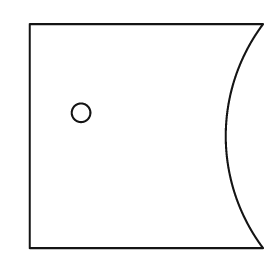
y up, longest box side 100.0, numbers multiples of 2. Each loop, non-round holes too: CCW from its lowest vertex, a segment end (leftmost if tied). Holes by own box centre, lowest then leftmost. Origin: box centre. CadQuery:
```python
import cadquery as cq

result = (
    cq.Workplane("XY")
    .moveTo(-50.0, -48.0)
    .lineTo(50.0, -48.0)
    .threePointArc((34.0, 0.0), (50.0, 48.0))
    .lineTo(-50.0, 48.0)
    .close()
    .moveTo(-28.0, 10.0)
    .circle(4.0)
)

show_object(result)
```